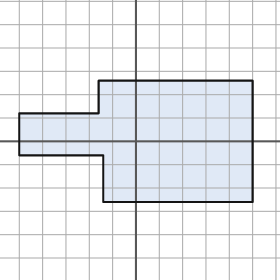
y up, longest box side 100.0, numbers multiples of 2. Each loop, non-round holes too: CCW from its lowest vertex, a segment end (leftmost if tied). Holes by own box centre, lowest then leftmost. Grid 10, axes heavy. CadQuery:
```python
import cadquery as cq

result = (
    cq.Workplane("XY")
    .moveTo(-14.0, -26.0)
    .lineTo(50.0, -26.0)
    .lineTo(50.0, 26.0)
    .lineTo(-16.0, 26.0)
    .lineTo(-16.0, 12.0)
    .lineTo(-50.0, 12.0)
    .lineTo(-50.0, -6.0)
    .lineTo(-14.0, -6.0)
    .close()
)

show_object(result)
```